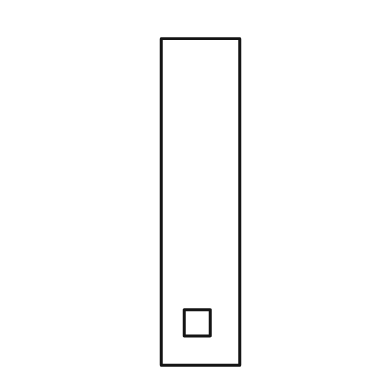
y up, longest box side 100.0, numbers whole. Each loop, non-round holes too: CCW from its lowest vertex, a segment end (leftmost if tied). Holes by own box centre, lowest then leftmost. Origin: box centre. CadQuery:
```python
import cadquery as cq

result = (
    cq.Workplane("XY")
    .moveTo(-12.0, -50.0)
    .lineTo(12.0, -50.0)
    .lineTo(12.0, 50.0)
    .lineTo(-12.0, 50.0)
    .close()
    .moveTo(-5.0, -41.0)
    .lineTo(3.0, -41.0)
    .lineTo(3.0, -33.0)
    .lineTo(-5.0, -33.0)
    .close()
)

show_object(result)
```